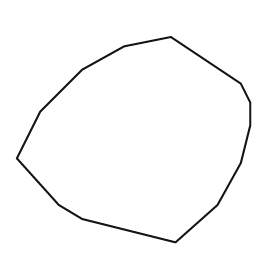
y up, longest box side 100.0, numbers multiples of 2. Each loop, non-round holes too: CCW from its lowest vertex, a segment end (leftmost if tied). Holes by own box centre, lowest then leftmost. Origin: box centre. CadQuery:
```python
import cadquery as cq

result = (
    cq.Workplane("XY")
    .moveTo(18.0, -44.0)
    .lineTo(36.0, -28.0)
    .lineTo(46.0, -10.0)
    .lineTo(50.0, 6.0)
    .lineTo(50.0, 16.0)
    .lineTo(46.0, 24.0)
    .lineTo(16.0, 44.0)
    .lineTo(-4.0, 40.0)
    .lineTo(-22.0, 30.0)
    .lineTo(-40.0, 12.0)
    .lineTo(-50.0, -8.0)
    .lineTo(-32.0, -28.0)
    .lineTo(-22.0, -34.0)
    .close()
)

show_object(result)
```